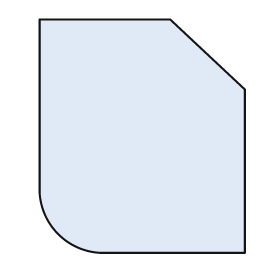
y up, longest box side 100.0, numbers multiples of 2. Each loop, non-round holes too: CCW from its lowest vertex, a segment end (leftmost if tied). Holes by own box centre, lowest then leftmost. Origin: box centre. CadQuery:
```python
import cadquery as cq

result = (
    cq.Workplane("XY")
    .moveTo(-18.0, -50.0)
    .lineTo(44.0, -50.0)
    .lineTo(44.0, 20.0)
    .lineTo(12.0, 50.0)
    .lineTo(-44.0, 50.0)
    .lineTo(-44.0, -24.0)
    .threePointArc((-36.0, -42.0), (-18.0, -50.0))
    .close()
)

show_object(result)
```